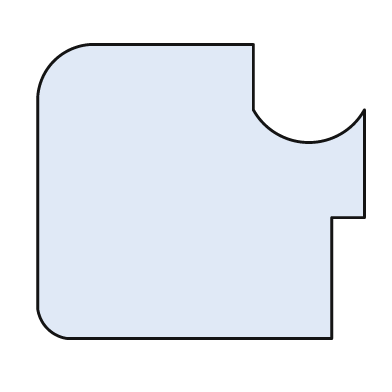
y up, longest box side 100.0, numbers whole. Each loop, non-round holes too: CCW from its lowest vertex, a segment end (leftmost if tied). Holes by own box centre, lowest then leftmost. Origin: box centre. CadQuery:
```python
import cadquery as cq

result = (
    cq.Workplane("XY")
    .moveTo(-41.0, -45.0)
    .lineTo(40.0, -45.0)
    .lineTo(40.0, -8.0)
    .lineTo(50.0, -8.0)
    .lineTo(50.0, 25.0)
    .threePointArc((33.0, 15.0), (16.0, 25.0))
    .lineTo(16.0, 45.0)
    .lineTo(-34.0, 45.0)
    .threePointArc((-45.0, 40.0), (-50.0, 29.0))
    .lineTo(-50.0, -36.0)
    .threePointArc((-47.0, -42.0), (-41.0, -45.0))
    .close()
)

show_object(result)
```